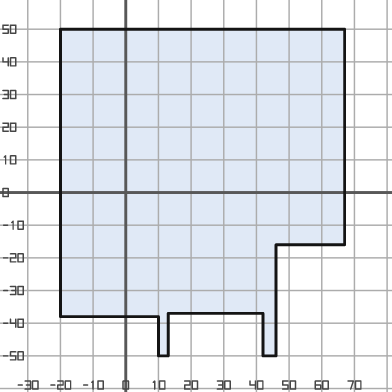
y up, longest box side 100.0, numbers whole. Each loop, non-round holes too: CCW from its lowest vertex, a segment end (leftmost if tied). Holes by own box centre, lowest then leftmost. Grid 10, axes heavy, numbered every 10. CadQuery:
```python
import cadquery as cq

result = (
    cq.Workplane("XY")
    .moveTo(10.0, -50.0)
    .lineTo(13.0, -50.0)
    .lineTo(13.0, -37.0)
    .lineTo(42.0, -37.0)
    .lineTo(42.0, -50.0)
    .lineTo(46.0, -50.0)
    .lineTo(46.0, -16.0)
    .lineTo(67.0, -16.0)
    .lineTo(67.0, 50.0)
    .lineTo(-20.0, 50.0)
    .lineTo(-20.0, -38.0)
    .lineTo(10.0, -38.0)
    .close()
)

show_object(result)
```